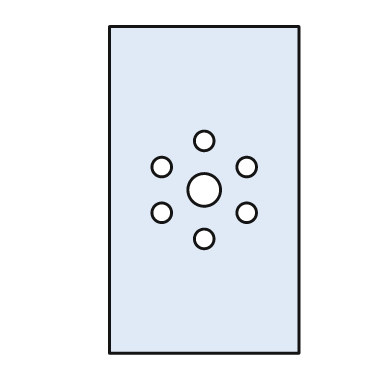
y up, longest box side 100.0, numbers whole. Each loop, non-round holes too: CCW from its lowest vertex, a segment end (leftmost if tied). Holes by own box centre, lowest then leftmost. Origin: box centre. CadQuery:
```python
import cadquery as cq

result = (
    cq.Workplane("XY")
    .moveTo(-29.0, -50.0)
    .lineTo(29.0, -50.0)
    .lineTo(29.0, 50.0)
    .lineTo(-29.0, 50.0)
    .close()
    .moveTo(0.0, -15.0)
    .circle(3.0)
    .moveTo(-13.0, -7.0)
    .circle(3.0)
    .moveTo(13.0, -7.0)
    .circle(3.0)
    .moveTo(0.0, 0.0)
    .circle(5.0)
    .moveTo(-13.0, 7.0)
    .circle(3.0)
    .moveTo(13.0, 7.0)
    .circle(3.0)
    .moveTo(0.0, 15.0)
    .circle(3.0)
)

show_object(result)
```